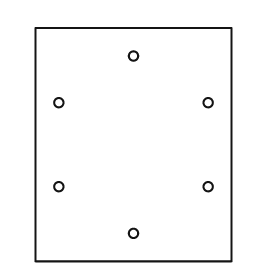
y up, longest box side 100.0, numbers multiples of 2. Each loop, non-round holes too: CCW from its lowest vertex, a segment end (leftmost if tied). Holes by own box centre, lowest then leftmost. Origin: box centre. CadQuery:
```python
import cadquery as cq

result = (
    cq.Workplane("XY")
    .moveTo(-42.0, -50.0)
    .lineTo(42.0, -50.0)
    .lineTo(42.0, 50.0)
    .lineTo(-42.0, 50.0)
    .close()
    .moveTo(0.0, -38.0)
    .circle(2.0)
    .moveTo(-32.0, -18.0)
    .circle(2.0)
    .moveTo(32.0, -18.0)
    .circle(2.0)
    .moveTo(-32.0, 18.0)
    .circle(2.0)
    .moveTo(32.0, 18.0)
    .circle(2.0)
    .moveTo(0.0, 38.0)
    .circle(2.0)
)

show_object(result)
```